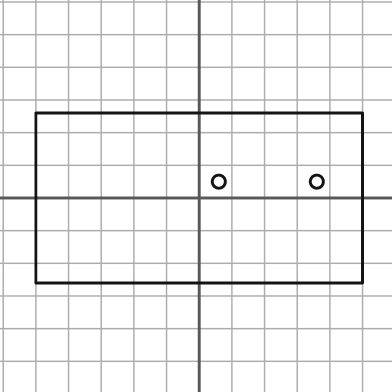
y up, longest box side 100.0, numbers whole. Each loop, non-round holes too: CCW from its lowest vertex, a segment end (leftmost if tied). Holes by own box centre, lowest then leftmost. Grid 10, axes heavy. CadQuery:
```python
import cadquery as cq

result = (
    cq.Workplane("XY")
    .moveTo(-50.0, -26.0)
    .lineTo(50.0, -26.0)
    .lineTo(50.0, 26.0)
    .lineTo(-50.0, 26.0)
    .close()
    .moveTo(6.0, 5.0)
    .circle(2.0)
    .moveTo(36.0, 5.0)
    .circle(2.0)
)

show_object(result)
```